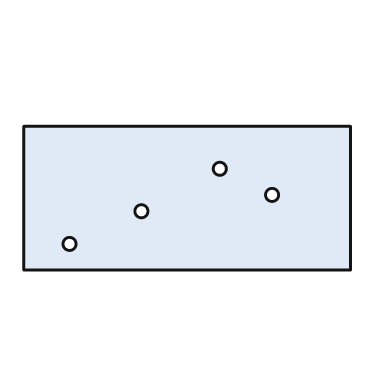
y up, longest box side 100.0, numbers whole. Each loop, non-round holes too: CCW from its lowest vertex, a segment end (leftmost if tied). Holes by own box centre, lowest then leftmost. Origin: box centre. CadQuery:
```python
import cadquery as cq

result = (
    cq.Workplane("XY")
    .moveTo(-50.0, -22.0)
    .lineTo(50.0, -22.0)
    .lineTo(50.0, 22.0)
    .lineTo(-50.0, 22.0)
    .close()
    .moveTo(-36.0, -14.0)
    .circle(2.0)
    .moveTo(-14.0, -4.0)
    .circle(2.0)
    .moveTo(26.0, 1.0)
    .circle(2.0)
    .moveTo(10.0, 9.0)
    .circle(2.0)
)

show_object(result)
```